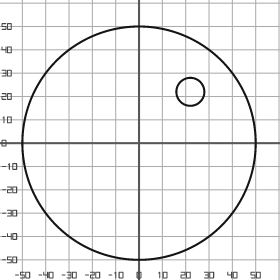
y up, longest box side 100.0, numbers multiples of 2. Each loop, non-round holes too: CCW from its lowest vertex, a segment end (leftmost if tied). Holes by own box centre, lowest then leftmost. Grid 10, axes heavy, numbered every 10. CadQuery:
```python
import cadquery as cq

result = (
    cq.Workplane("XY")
    .moveTo(0.0, 0.0)
    .circle(50.0)
    .moveTo(22.0, 22.0)
    .circle(6.0)
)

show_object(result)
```